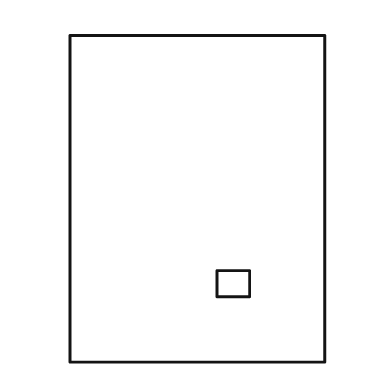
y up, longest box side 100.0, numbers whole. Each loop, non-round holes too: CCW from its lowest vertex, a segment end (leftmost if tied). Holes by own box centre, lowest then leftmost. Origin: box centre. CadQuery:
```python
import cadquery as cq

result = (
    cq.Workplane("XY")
    .moveTo(-39.0, -50.0)
    .lineTo(39.0, -50.0)
    .lineTo(39.0, 50.0)
    .lineTo(-39.0, 50.0)
    .close()
    .moveTo(6.0, -30.0)
    .lineTo(16.0, -30.0)
    .lineTo(16.0, -22.0)
    .lineTo(6.0, -22.0)
    .close()
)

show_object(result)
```